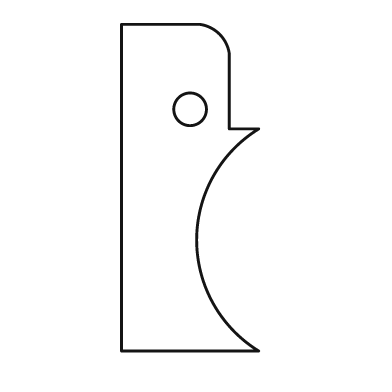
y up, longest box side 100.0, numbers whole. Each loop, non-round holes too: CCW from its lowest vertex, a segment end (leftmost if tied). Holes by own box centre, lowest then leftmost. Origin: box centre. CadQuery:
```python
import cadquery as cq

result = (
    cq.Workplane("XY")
    .moveTo(-21.0, -50.0)
    .lineTo(21.0, -50.0)
    .threePointArc((2.0, -16.0), (21.0, 18.0))
    .lineTo(12.0, 18.0)
    .lineTo(12.0, 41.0)
    .threePointArc((9.0, 47.0), (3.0, 50.0))
    .lineTo(-21.0, 50.0)
    .close()
    .moveTo(0.0, 24.0)
    .circle(5.0)
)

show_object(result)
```